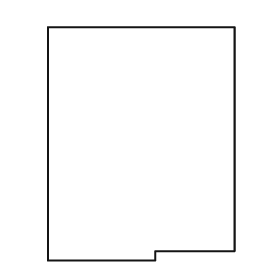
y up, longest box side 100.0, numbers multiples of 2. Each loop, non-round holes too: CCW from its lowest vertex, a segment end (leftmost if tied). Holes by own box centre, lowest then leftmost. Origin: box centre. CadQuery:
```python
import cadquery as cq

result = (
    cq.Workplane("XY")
    .moveTo(-40.0, -50.0)
    .lineTo(6.0, -50.0)
    .lineTo(6.0, -46.0)
    .lineTo(40.0, -46.0)
    .lineTo(40.0, 50.0)
    .lineTo(-40.0, 50.0)
    .close()
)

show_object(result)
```